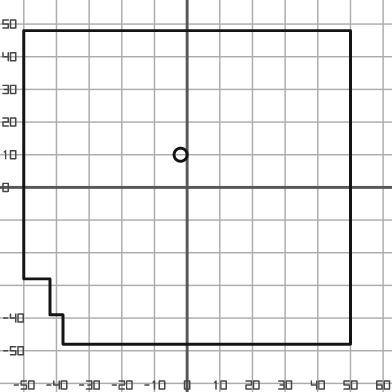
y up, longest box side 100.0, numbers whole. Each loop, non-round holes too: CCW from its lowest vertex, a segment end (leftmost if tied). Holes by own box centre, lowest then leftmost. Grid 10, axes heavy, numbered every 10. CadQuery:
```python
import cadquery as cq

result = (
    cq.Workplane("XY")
    .moveTo(-38.0, -48.0)
    .lineTo(50.0, -48.0)
    .lineTo(50.0, 48.0)
    .lineTo(-50.0, 48.0)
    .lineTo(-50.0, -28.0)
    .lineTo(-42.0, -28.0)
    .lineTo(-42.0, -39.0)
    .lineTo(-38.0, -39.0)
    .close()
    .moveTo(-2.0, 10.0)
    .circle(2.0)
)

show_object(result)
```